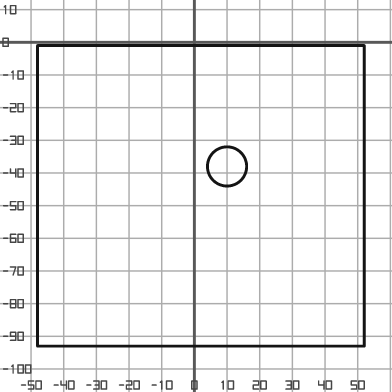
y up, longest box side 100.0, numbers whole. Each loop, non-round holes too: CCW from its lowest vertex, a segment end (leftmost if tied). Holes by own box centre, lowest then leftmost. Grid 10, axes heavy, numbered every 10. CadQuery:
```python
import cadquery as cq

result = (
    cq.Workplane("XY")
    .moveTo(-48.0, -93.0)
    .lineTo(52.0, -93.0)
    .lineTo(52.0, -1.0)
    .lineTo(-48.0, -1.0)
    .close()
    .moveTo(10.0, -38.0)
    .circle(6.0)
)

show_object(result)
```